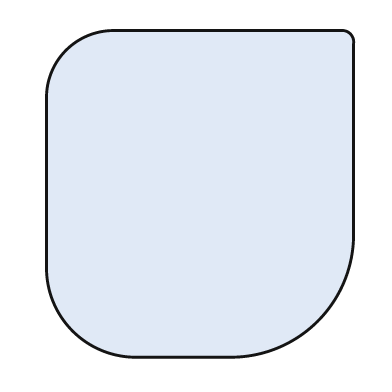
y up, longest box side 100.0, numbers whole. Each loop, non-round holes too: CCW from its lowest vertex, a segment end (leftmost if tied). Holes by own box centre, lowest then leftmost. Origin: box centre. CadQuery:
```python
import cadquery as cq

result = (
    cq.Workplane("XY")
    .moveTo(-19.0, -50.0)
    .lineTo(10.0, -50.0)
    .threePointArc((36.0, -39.0), (47.0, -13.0))
    .lineTo(47.0, 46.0)
    .threePointArc((46.0, 49.0), (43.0, 50.0))
    .lineTo(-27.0, 50.0)
    .threePointArc((-41.0, 44.0), (-47.0, 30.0))
    .lineTo(-47.0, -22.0)
    .threePointArc((-39.0, -42.0), (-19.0, -50.0))
    .close()
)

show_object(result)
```